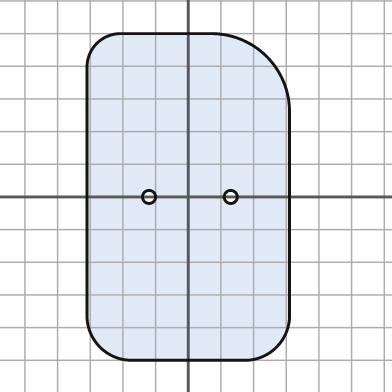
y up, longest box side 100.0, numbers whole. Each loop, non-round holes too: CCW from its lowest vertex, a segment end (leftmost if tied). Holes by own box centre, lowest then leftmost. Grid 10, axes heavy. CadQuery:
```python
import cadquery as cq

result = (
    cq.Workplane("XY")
    .moveTo(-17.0, -50.0)
    .lineTo(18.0, -50.0)
    .threePointArc((27.0, -46.0), (31.0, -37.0))
    .lineTo(31.0, 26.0)
    .threePointArc((24.0, 43.0), (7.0, 50.0))
    .lineTo(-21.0, 50.0)
    .threePointArc((-28.0, 47.0), (-31.0, 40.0))
    .lineTo(-31.0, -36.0)
    .threePointArc((-27.0, -46.0), (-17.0, -50.0))
    .close()
    .moveTo(-12.0, 0.0)
    .circle(2.0)
    .moveTo(13.0, 0.0)
    .circle(2.0)
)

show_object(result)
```